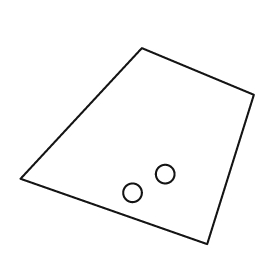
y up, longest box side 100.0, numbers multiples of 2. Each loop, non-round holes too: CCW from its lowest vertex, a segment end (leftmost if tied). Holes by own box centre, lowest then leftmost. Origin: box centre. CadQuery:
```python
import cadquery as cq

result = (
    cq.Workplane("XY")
    .moveTo(30.0, -42.0)
    .lineTo(50.0, 22.0)
    .lineTo(2.0, 42.0)
    .lineTo(-50.0, -14.0)
    .close()
    .moveTo(-2.0, -20.0)
    .circle(4.0)
    .moveTo(12.0, -12.0)
    .circle(4.0)
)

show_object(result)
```